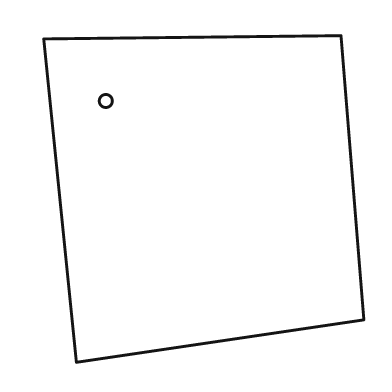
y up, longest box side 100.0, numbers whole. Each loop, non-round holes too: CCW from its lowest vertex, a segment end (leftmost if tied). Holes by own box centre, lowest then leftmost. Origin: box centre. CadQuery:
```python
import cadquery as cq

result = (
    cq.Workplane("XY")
    .moveTo(-39.0, -50.0)
    .lineTo(49.0, -37.0)
    .lineTo(42.0, 50.0)
    .lineTo(-49.0, 49.0)
    .close()
    .moveTo(-30.0, 30.0)
    .circle(2.0)
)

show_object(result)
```